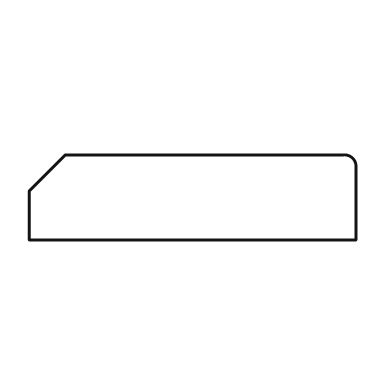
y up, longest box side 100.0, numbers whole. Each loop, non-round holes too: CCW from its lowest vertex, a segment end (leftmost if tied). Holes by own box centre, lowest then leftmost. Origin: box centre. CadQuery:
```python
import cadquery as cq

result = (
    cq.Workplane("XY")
    .moveTo(-50.0, -13.0)
    .lineTo(50.0, -13.0)
    .lineTo(50.0, 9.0)
    .threePointArc((49.0, 12.0), (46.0, 13.0))
    .lineTo(-39.0, 13.0)
    .lineTo(-50.0, 2.0)
    .close()
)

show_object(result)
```